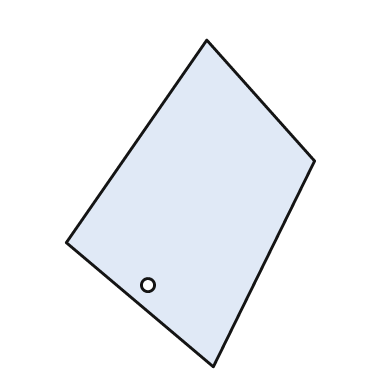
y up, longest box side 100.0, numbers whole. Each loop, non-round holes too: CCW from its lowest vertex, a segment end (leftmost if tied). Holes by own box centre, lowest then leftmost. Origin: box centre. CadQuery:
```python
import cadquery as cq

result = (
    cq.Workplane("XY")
    .moveTo(7.0, -50.0)
    .lineTo(38.0, 13.0)
    .lineTo(5.0, 50.0)
    .lineTo(-38.0, -12.0)
    .close()
    .moveTo(-13.0, -25.0)
    .circle(2.0)
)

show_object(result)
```